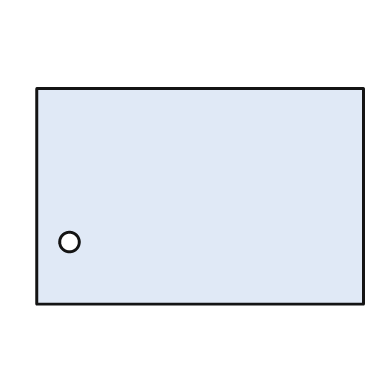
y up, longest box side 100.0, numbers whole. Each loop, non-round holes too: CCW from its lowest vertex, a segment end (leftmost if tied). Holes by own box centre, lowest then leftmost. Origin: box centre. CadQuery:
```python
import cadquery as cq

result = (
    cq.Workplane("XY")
    .moveTo(-50.0, -33.0)
    .lineTo(50.0, -33.0)
    .lineTo(50.0, 33.0)
    .lineTo(-50.0, 33.0)
    .close()
    .moveTo(-40.0, -14.0)
    .circle(3.0)
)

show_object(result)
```